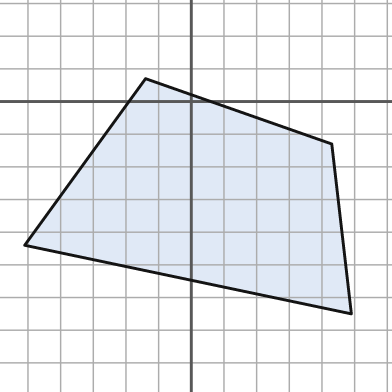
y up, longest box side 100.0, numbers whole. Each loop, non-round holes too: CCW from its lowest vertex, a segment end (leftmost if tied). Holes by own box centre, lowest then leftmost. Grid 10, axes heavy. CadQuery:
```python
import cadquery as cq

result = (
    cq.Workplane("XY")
    .moveTo(49.0, -65.0)
    .lineTo(43.0, -13.0)
    .lineTo(-14.0, 7.0)
    .lineTo(-51.0, -44.0)
    .close()
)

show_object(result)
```